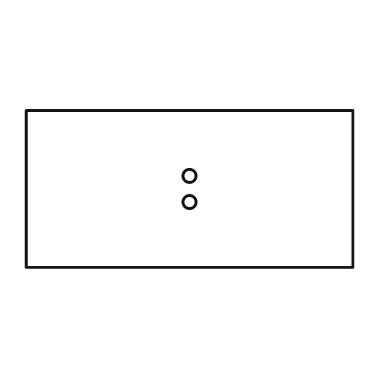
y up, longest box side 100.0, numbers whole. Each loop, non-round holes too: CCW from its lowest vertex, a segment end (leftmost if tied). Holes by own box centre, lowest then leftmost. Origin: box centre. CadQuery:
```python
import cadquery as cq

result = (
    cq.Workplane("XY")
    .moveTo(-50.0, -24.0)
    .lineTo(50.0, -24.0)
    .lineTo(50.0, 24.0)
    .lineTo(-50.0, 24.0)
    .close()
    .moveTo(0.0, -4.0)
    .circle(2.0)
    .moveTo(0.0, 4.0)
    .circle(2.0)
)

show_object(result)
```